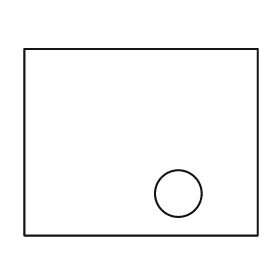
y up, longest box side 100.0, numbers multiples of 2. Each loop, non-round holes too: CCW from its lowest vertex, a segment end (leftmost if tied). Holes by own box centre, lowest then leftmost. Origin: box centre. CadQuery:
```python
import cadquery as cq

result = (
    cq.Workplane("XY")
    .moveTo(-50.0, -40.0)
    .lineTo(50.0, -40.0)
    .lineTo(50.0, 40.0)
    .lineTo(-50.0, 40.0)
    .close()
    .moveTo(16.0, -22.0)
    .circle(10.0)
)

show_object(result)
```